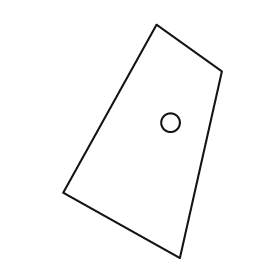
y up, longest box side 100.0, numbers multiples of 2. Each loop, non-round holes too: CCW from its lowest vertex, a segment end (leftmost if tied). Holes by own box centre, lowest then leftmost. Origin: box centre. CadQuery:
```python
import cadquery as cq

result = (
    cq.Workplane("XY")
    .moveTo(16.0, -50.0)
    .lineTo(34.0, 30.0)
    .lineTo(6.0, 50.0)
    .lineTo(-34.0, -22.0)
    .close()
    .moveTo(12.0, 8.0)
    .circle(4.0)
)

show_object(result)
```